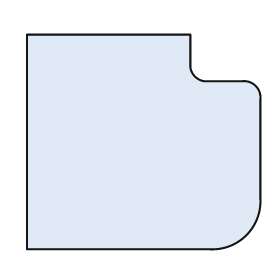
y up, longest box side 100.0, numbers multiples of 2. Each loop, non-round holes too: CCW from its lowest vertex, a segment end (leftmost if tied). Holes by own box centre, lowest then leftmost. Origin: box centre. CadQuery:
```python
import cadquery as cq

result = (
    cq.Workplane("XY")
    .moveTo(-50.0, -46.0)
    .lineTo(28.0, -46.0)
    .threePointArc((44.0, -40.0), (50.0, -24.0))
    .lineTo(50.0, 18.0)
    .threePointArc((48.0, 24.0), (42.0, 26.0))
    .lineTo(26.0, 26.0)
    .threePointArc((22.0, 28.0), (20.0, 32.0))
    .lineTo(20.0, 46.0)
    .lineTo(-50.0, 46.0)
    .close()
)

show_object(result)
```